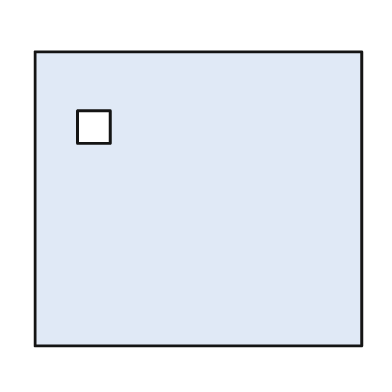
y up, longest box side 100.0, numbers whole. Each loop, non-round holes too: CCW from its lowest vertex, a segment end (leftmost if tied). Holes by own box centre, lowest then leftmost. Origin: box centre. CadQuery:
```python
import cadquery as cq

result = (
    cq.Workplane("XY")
    .moveTo(-50.0, -45.0)
    .lineTo(50.0, -45.0)
    .lineTo(50.0, 45.0)
    .lineTo(-50.0, 45.0)
    .close()
    .moveTo(-37.0, 17.0)
    .lineTo(-27.0, 17.0)
    .lineTo(-27.0, 27.0)
    .lineTo(-37.0, 27.0)
    .close()
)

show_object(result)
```